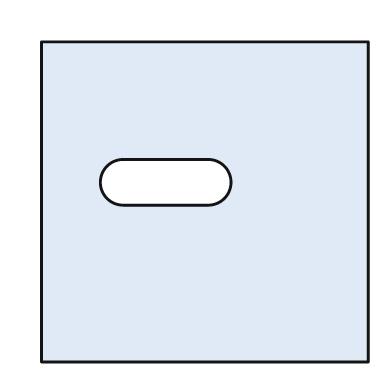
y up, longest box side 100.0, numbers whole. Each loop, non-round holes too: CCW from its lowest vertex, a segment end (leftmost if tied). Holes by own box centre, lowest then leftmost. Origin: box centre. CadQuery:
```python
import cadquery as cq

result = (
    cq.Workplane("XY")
    .moveTo(-50.0, -49.0)
    .lineTo(50.0, -49.0)
    .lineTo(50.0, 49.0)
    .lineTo(-50.0, 49.0)
    .close()
    .moveTo(-25.0, -1.0)
    .lineTo(1.0, -1.0)
    .threePointArc((8.0, 6.0), (1.0, 13.0))
    .lineTo(-25.0, 13.0)
    .threePointArc((-32.0, 6.0), (-25.0, -1.0))
    .close()
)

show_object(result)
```